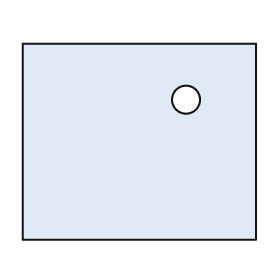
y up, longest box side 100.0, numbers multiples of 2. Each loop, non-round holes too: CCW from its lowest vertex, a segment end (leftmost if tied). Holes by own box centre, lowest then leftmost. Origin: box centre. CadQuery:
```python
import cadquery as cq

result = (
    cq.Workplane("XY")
    .moveTo(-50.0, -42.0)
    .lineTo(50.0, -42.0)
    .lineTo(50.0, 42.0)
    .lineTo(-50.0, 42.0)
    .close()
    .moveTo(20.0, 18.0)
    .circle(6.0)
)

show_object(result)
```